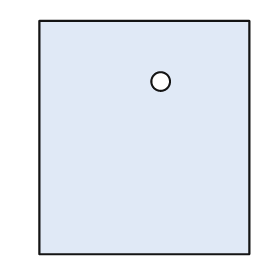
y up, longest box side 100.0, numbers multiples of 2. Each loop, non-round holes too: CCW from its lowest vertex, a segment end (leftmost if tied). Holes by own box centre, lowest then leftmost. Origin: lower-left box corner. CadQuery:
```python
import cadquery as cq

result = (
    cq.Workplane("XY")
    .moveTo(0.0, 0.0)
    .lineTo(90.0, 0.0)
    .lineTo(90.0, 100.0)
    .lineTo(0.0, 100.0)
    .close()
    .moveTo(52.0, 74.0)
    .circle(4.0)
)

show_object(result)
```